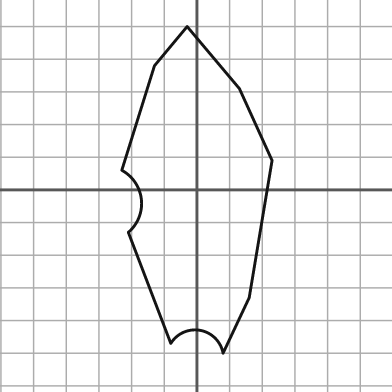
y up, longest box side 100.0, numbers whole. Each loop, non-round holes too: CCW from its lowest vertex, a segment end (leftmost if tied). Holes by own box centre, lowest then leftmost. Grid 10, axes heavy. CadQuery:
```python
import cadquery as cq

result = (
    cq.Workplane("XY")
    .moveTo(8.0, -50.0)
    .lineTo(16.0, -33.0)
    .lineTo(23.0, 9.0)
    .lineTo(13.0, 31.0)
    .lineTo(-3.0, 50.0)
    .lineTo(-13.0, 38.0)
    .lineTo(-23.0, 6.0)
    .threePointArc((-17.0, -3.0), (-21.0, -13.0))
    .lineTo(-8.0, -47.0)
    .threePointArc((1.0, -43.0), (8.0, -50.0))
    .close()
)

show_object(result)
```